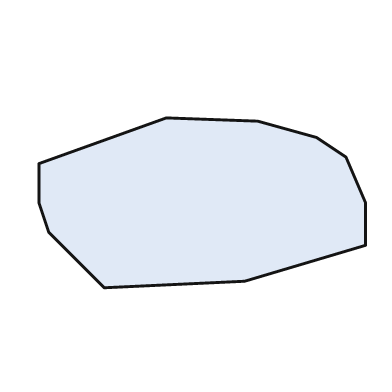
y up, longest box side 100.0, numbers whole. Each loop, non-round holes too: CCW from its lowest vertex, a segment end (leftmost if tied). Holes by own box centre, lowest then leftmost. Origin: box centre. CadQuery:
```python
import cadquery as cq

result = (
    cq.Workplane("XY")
    .moveTo(-30.0, -26.0)
    .lineTo(13.0, -24.0)
    .lineTo(50.0, -13.0)
    .lineTo(50.0, 0.0)
    .lineTo(44.0, 14.0)
    .lineTo(35.0, 20.0)
    .lineTo(17.0, 25.0)
    .lineTo(-11.0, 26.0)
    .lineTo(-50.0, 12.0)
    .lineTo(-50.0, 0.0)
    .lineTo(-47.0, -9.0)
    .close()
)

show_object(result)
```